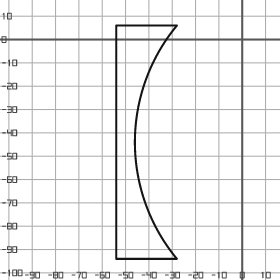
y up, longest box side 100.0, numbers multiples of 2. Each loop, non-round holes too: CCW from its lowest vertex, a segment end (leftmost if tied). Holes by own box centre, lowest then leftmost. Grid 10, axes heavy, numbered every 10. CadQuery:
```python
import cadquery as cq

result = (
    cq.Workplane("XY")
    .moveTo(-54.0, -94.0)
    .lineTo(-28.0, -94.0)
    .threePointArc((-46.0, -44.0), (-28.0, 6.0))
    .lineTo(-54.0, 6.0)
    .close()
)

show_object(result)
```